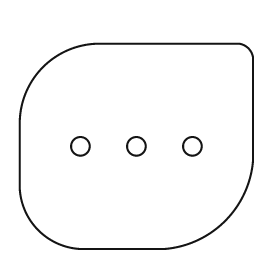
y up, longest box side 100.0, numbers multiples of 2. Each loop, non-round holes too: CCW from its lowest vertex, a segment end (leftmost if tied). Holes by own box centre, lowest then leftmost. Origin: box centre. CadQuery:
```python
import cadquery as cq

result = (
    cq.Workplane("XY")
    .moveTo(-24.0, -44.0)
    .lineTo(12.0, -44.0)
    .threePointArc((38.0, -32.0), (50.0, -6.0))
    .lineTo(50.0, 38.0)
    .threePointArc((48.0, 42.0), (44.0, 44.0))
    .lineTo(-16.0, 44.0)
    .threePointArc((-40.0, 34.0), (-50.0, 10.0))
    .lineTo(-50.0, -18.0)
    .threePointArc((-42.0, -36.0), (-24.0, -44.0))
    .close()
    .moveTo(-24.0, 0.0)
    .circle(4.0)
    .moveTo(0.0, 0.0)
    .circle(4.0)
    .moveTo(24.0, 0.0)
    .circle(4.0)
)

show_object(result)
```